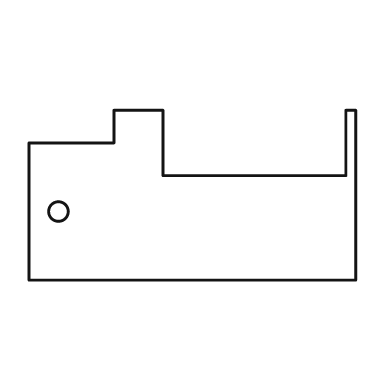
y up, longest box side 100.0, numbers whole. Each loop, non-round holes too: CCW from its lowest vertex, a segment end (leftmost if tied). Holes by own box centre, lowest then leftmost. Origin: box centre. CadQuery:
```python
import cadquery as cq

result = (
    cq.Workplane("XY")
    .moveTo(-50.0, -26.0)
    .lineTo(50.0, -26.0)
    .lineTo(50.0, 26.0)
    .lineTo(47.0, 26.0)
    .lineTo(47.0, 6.0)
    .lineTo(-9.0, 6.0)
    .lineTo(-9.0, 26.0)
    .lineTo(-24.0, 26.0)
    .lineTo(-24.0, 16.0)
    .lineTo(-50.0, 16.0)
    .close()
    .moveTo(-41.0, -5.0)
    .circle(3.0)
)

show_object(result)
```